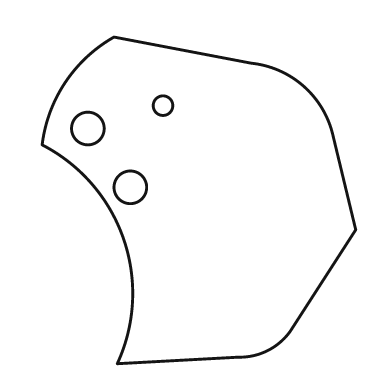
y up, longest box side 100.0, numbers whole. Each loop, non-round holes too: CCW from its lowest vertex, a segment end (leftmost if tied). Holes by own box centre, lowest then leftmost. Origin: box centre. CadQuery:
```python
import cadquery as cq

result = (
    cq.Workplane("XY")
    .moveTo(-25.0, -50.0)
    .lineTo(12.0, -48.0)
    .threePointArc((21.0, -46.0), (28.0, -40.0))
    .lineTo(48.0, -9.0)
    .lineTo(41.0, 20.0)
    .threePointArc((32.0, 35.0), (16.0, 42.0))
    .lineTo(-26.0, 50.0)
    .threePointArc((-41.0, 36.0), (-48.0, 17.0))
    .threePointArc((-23.0, -12.0), (-25.0, -50.0))
    .close()
    .moveTo(-21.0, 4.0)
    .circle(5.0)
    .moveTo(-34.0, 22.0)
    .circle(5.0)
    .moveTo(-11.0, 29.0)
    .circle(3.0)
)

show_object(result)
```